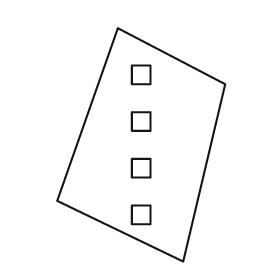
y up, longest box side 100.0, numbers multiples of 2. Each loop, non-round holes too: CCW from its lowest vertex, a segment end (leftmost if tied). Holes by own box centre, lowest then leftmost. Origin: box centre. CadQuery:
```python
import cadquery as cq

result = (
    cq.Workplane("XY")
    .moveTo(18.0, -50.0)
    .lineTo(36.0, 26.0)
    .lineTo(-10.0, 50.0)
    .lineTo(-36.0, -24.0)
    .close()
    .moveTo(-4.0, -34.0)
    .lineTo(4.0, -34.0)
    .lineTo(4.0, -26.0)
    .lineTo(-4.0, -26.0)
    .close()
    .moveTo(-4.0, -14.0)
    .lineTo(4.0, -14.0)
    .lineTo(4.0, -6.0)
    .lineTo(-4.0, -6.0)
    .close()
    .moveTo(-4.0, 6.0)
    .lineTo(4.0, 6.0)
    .lineTo(4.0, 14.0)
    .lineTo(-4.0, 14.0)
    .close()
    .moveTo(-4.0, 26.0)
    .lineTo(4.0, 26.0)
    .lineTo(4.0, 34.0)
    .lineTo(-4.0, 34.0)
    .close()
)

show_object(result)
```